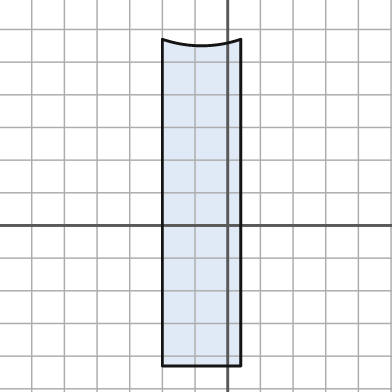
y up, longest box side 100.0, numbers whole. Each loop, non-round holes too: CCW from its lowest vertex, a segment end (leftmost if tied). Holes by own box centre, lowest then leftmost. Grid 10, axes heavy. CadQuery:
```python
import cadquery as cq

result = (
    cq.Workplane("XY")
    .moveTo(-20.0, -43.0)
    .lineTo(4.0, -43.0)
    .lineTo(4.0, 57.0)
    .threePointArc((-8.0, 55.0), (-20.0, 57.0))
    .close()
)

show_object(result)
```